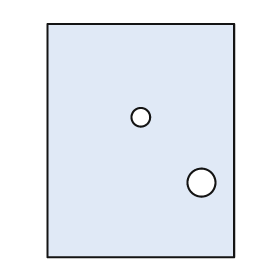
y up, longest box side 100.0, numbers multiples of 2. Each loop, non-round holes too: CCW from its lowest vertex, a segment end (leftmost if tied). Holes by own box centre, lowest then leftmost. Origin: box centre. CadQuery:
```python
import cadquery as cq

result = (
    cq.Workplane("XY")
    .moveTo(-40.0, -50.0)
    .lineTo(40.0, -50.0)
    .lineTo(40.0, 50.0)
    .lineTo(-40.0, 50.0)
    .close()
    .moveTo(26.0, -18.0)
    .circle(6.0)
    .moveTo(0.0, 10.0)
    .circle(4.0)
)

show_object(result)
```